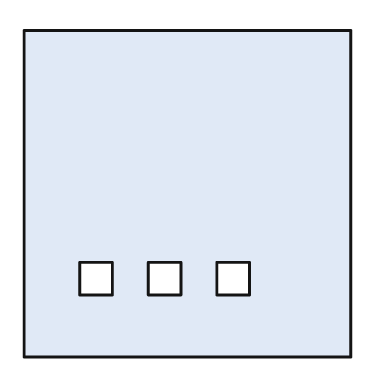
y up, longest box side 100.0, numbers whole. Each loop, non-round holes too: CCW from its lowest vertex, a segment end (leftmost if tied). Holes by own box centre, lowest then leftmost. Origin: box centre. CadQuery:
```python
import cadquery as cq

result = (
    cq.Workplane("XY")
    .moveTo(-50.0, -50.0)
    .lineTo(50.0, -50.0)
    .lineTo(50.0, 50.0)
    .lineTo(-50.0, 50.0)
    .close()
    .moveTo(-33.0, -31.0)
    .lineTo(-23.0, -31.0)
    .lineTo(-23.0, -21.0)
    .lineTo(-33.0, -21.0)
    .close()
    .moveTo(-12.0, -31.0)
    .lineTo(-2.0, -31.0)
    .lineTo(-2.0, -21.0)
    .lineTo(-12.0, -21.0)
    .close()
    .moveTo(9.0, -31.0)
    .lineTo(19.0, -31.0)
    .lineTo(19.0, -21.0)
    .lineTo(9.0, -21.0)
    .close()
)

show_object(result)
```